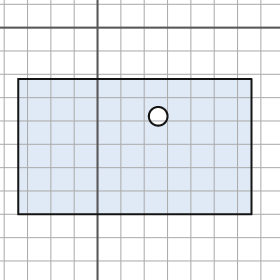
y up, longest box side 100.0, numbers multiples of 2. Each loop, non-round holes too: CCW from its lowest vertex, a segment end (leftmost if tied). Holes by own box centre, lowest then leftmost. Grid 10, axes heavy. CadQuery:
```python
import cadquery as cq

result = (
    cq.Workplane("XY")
    .moveTo(-34.0, -80.0)
    .lineTo(66.0, -80.0)
    .lineTo(66.0, -22.0)
    .lineTo(-34.0, -22.0)
    .close()
    .moveTo(26.0, -38.0)
    .circle(4.0)
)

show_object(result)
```